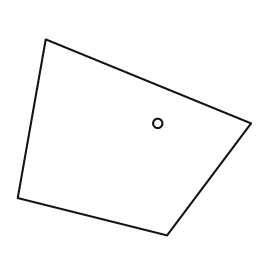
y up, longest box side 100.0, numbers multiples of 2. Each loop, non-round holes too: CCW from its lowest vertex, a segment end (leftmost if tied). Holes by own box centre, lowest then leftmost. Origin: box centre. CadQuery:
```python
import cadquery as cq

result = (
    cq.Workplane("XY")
    .moveTo(14.0, -42.0)
    .lineTo(50.0, 6.0)
    .lineTo(-38.0, 42.0)
    .lineTo(-50.0, -26.0)
    .close()
    .moveTo(10.0, 6.0)
    .circle(2.0)
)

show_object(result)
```